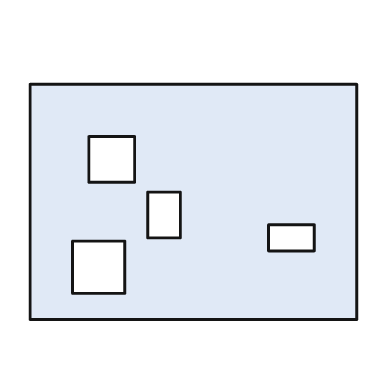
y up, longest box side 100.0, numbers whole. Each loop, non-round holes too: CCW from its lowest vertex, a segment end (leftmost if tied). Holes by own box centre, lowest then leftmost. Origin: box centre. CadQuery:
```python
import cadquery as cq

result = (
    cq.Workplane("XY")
    .moveTo(-50.0, -36.0)
    .lineTo(50.0, -36.0)
    .lineTo(50.0, 36.0)
    .lineTo(-50.0, 36.0)
    .close()
    .moveTo(-37.0, -28.0)
    .lineTo(-21.0, -28.0)
    .lineTo(-21.0, -12.0)
    .lineTo(-37.0, -12.0)
    .close()
    .moveTo(23.0, -15.0)
    .lineTo(37.0, -15.0)
    .lineTo(37.0, -7.0)
    .lineTo(23.0, -7.0)
    .close()
    .moveTo(-14.0, -11.0)
    .lineTo(-4.0, -11.0)
    .lineTo(-4.0, 3.0)
    .lineTo(-14.0, 3.0)
    .close()
    .moveTo(-32.0, 6.0)
    .lineTo(-18.0, 6.0)
    .lineTo(-18.0, 20.0)
    .lineTo(-32.0, 20.0)
    .close()
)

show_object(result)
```